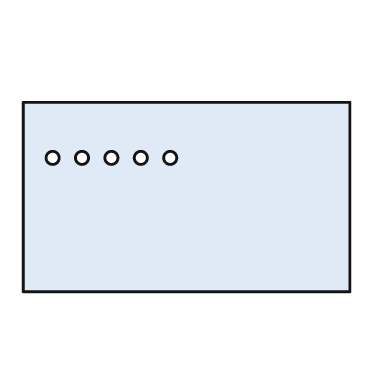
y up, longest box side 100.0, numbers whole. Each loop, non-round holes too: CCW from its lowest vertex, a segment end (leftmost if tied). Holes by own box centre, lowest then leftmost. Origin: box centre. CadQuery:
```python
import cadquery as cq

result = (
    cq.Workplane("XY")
    .moveTo(-50.0, -29.0)
    .lineTo(50.0, -29.0)
    .lineTo(50.0, 29.0)
    .lineTo(-50.0, 29.0)
    .close()
    .moveTo(-41.0, 12.0)
    .circle(2.0)
    .moveTo(-32.0, 12.0)
    .circle(2.0)
    .moveTo(-23.0, 12.0)
    .circle(2.0)
    .moveTo(-14.0, 12.0)
    .circle(2.0)
    .moveTo(-5.0, 12.0)
    .circle(2.0)
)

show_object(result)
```